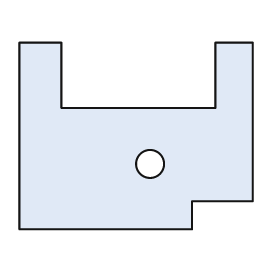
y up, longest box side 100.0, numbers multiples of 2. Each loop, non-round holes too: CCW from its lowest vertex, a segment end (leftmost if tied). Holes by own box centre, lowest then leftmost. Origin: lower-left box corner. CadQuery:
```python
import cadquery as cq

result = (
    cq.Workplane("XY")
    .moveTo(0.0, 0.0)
    .lineTo(74.0, 0.0)
    .lineTo(74.0, 12.0)
    .lineTo(100.0, 12.0)
    .lineTo(100.0, 80.0)
    .lineTo(84.0, 80.0)
    .lineTo(84.0, 52.0)
    .lineTo(18.0, 52.0)
    .lineTo(18.0, 80.0)
    .lineTo(0.0, 80.0)
    .close()
    .moveTo(56.0, 28.0)
    .circle(6.0)
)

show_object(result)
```